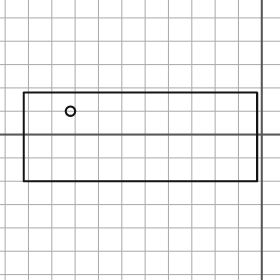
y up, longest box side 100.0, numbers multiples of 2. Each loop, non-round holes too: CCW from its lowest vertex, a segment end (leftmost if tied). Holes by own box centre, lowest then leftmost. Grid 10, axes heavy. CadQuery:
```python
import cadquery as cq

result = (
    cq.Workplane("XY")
    .moveTo(-102.0, -20.0)
    .lineTo(-2.0, -20.0)
    .lineTo(-2.0, 18.0)
    .lineTo(-102.0, 18.0)
    .close()
    .moveTo(-82.0, 10.0)
    .circle(2.0)
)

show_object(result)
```